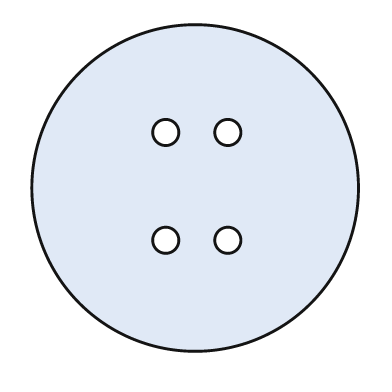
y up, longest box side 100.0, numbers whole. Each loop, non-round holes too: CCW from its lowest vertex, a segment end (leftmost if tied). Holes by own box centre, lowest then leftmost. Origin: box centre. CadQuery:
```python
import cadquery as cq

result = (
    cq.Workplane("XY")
    .moveTo(0.0, 0.0)
    .circle(50.0)
    .moveTo(-9.0, -16.0)
    .circle(4.0)
    .moveTo(10.0, -16.0)
    .circle(4.0)
    .moveTo(-9.0, 17.0)
    .circle(4.0)
    .moveTo(10.0, 17.0)
    .circle(4.0)
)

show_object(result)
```